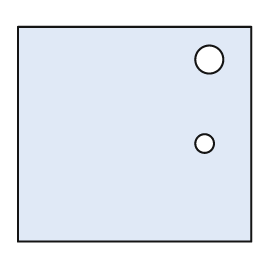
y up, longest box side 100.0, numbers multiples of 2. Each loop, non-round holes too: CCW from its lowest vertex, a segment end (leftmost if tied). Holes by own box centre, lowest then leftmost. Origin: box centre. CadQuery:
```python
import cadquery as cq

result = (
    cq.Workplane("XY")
    .moveTo(-50.0, -46.0)
    .lineTo(50.0, -46.0)
    .lineTo(50.0, 46.0)
    .lineTo(-50.0, 46.0)
    .close()
    .moveTo(30.0, -4.0)
    .circle(4.0)
    .moveTo(32.0, 32.0)
    .circle(6.0)
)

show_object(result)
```